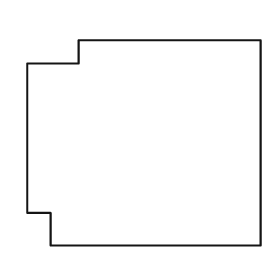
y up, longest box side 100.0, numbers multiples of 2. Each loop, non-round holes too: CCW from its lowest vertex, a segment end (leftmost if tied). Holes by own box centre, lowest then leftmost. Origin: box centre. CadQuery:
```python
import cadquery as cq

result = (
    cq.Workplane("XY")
    .moveTo(-40.0, -44.0)
    .lineTo(50.0, -44.0)
    .lineTo(50.0, 44.0)
    .lineTo(-28.0, 44.0)
    .lineTo(-28.0, 34.0)
    .lineTo(-50.0, 34.0)
    .lineTo(-50.0, -30.0)
    .lineTo(-40.0, -30.0)
    .close()
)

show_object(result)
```